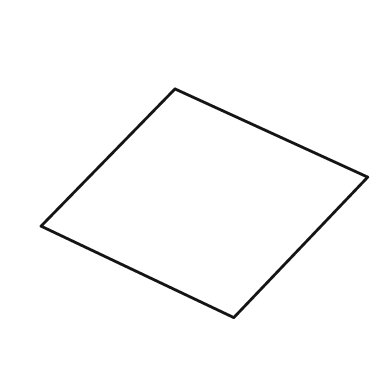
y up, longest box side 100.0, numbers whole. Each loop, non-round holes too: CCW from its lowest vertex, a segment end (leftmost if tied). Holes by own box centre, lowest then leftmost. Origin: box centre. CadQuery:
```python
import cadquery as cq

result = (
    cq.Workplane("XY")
    .moveTo(9.0, -35.0)
    .lineTo(50.0, 8.0)
    .lineTo(-9.0, 35.0)
    .lineTo(-50.0, -7.0)
    .close()
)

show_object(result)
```